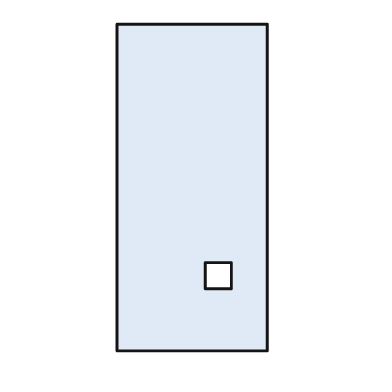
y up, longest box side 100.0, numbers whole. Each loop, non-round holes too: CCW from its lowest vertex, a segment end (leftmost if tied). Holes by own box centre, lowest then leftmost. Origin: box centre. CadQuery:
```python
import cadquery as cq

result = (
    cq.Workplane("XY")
    .moveTo(-23.0, -50.0)
    .lineTo(23.0, -50.0)
    .lineTo(23.0, 50.0)
    .lineTo(-23.0, 50.0)
    .close()
    .moveTo(4.0, -31.0)
    .lineTo(12.0, -31.0)
    .lineTo(12.0, -23.0)
    .lineTo(4.0, -23.0)
    .close()
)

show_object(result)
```